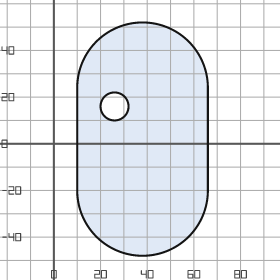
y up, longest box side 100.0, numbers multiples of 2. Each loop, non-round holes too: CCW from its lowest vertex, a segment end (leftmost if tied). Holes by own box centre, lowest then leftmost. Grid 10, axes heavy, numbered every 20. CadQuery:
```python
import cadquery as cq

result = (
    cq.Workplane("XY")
    .moveTo(10.0, -20.0)
    .threePointArc((38.0, -48.0), (66.0, -20.0))
    .lineTo(66.0, 24.0)
    .threePointArc((38.0, 52.0), (10.0, 24.0))
    .close()
    .moveTo(26.0, 16.0)
    .circle(6.0)
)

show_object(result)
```